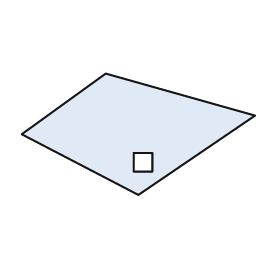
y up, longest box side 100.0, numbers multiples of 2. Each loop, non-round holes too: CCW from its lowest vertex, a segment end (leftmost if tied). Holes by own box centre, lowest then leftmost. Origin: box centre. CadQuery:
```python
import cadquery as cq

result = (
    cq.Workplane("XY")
    .moveTo(0.0, -26.0)
    .lineTo(50.0, 8.0)
    .lineTo(-14.0, 26.0)
    .lineTo(-50.0, 0.0)
    .close()
    .moveTo(-2.0, -16.0)
    .lineTo(6.0, -16.0)
    .lineTo(6.0, -8.0)
    .lineTo(-2.0, -8.0)
    .close()
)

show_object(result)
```